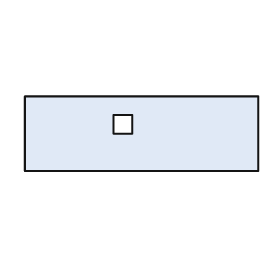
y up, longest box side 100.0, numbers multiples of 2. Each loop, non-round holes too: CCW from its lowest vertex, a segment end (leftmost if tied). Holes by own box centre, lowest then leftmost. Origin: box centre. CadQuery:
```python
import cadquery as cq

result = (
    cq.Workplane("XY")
    .moveTo(-50.0, -16.0)
    .lineTo(50.0, -16.0)
    .lineTo(50.0, 16.0)
    .lineTo(-50.0, 16.0)
    .close()
    .moveTo(-12.0, 0.0)
    .lineTo(-4.0, 0.0)
    .lineTo(-4.0, 8.0)
    .lineTo(-12.0, 8.0)
    .close()
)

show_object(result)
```